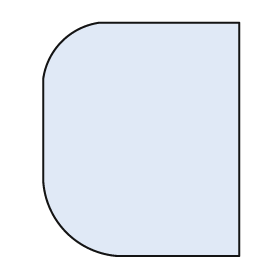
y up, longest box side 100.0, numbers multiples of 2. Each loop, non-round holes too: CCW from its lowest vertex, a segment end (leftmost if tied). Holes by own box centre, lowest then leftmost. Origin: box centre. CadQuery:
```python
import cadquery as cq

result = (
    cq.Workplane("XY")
    .moveTo(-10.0, -50.0)
    .lineTo(42.0, -50.0)
    .lineTo(42.0, 50.0)
    .lineTo(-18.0, 50.0)
    .threePointArc((-34.0, 42.0), (-42.0, 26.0))
    .lineTo(-42.0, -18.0)
    .threePointArc((-32.0, -40.0), (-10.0, -50.0))
    .close()
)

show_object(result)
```